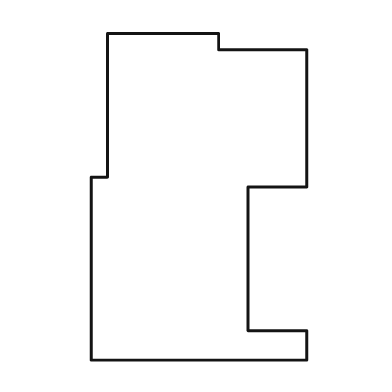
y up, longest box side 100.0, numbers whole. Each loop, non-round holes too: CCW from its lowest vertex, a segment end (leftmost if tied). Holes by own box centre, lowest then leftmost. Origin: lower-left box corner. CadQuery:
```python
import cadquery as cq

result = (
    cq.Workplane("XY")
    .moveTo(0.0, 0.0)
    .lineTo(66.0, 0.0)
    .lineTo(66.0, 9.0)
    .lineTo(48.0, 9.0)
    .lineTo(48.0, 53.0)
    .lineTo(66.0, 53.0)
    .lineTo(66.0, 95.0)
    .lineTo(39.0, 95.0)
    .lineTo(39.0, 100.0)
    .lineTo(5.0, 100.0)
    .lineTo(5.0, 56.0)
    .lineTo(0.0, 56.0)
    .close()
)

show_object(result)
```